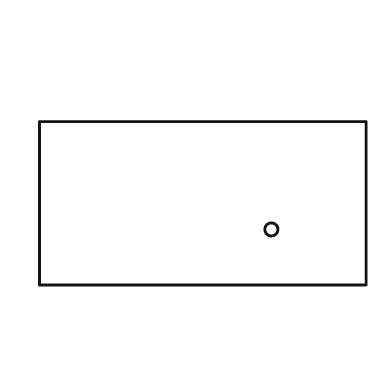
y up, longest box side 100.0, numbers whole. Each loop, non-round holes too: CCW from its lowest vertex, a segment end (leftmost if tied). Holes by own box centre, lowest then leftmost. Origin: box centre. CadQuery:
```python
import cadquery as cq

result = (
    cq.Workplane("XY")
    .moveTo(-50.0, -25.0)
    .lineTo(50.0, -25.0)
    .lineTo(50.0, 25.0)
    .lineTo(-50.0, 25.0)
    .close()
    .moveTo(21.0, -8.0)
    .circle(2.0)
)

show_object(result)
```